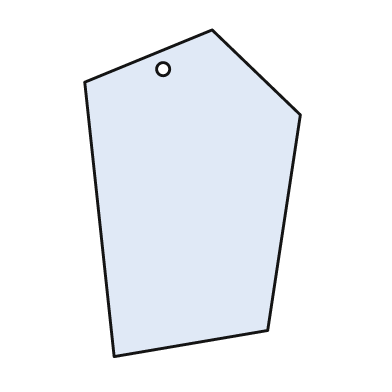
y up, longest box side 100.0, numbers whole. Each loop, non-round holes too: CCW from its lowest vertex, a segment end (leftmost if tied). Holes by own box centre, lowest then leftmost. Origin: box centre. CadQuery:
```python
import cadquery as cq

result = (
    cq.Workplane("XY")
    .moveTo(-24.0, -50.0)
    .lineTo(23.0, -42.0)
    .lineTo(33.0, 24.0)
    .lineTo(6.0, 50.0)
    .lineTo(-33.0, 34.0)
    .close()
    .moveTo(-9.0, 38.0)
    .circle(2.0)
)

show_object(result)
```